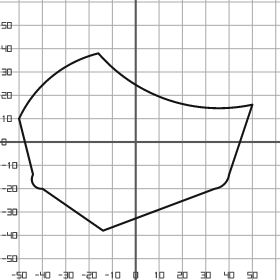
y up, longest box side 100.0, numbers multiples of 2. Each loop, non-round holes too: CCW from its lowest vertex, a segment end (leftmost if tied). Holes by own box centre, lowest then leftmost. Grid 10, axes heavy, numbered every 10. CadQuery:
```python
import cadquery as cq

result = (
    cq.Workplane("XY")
    .moveTo(-14.0, -38.0)
    .lineTo(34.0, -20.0)
    .threePointArc((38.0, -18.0), (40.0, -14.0))
    .lineTo(50.0, 16.0)
    .threePointArc((14.0, 18.0), (-16.0, 38.0))
    .threePointArc((-36.0, 28.0), (-50.0, 10.0))
    .lineTo(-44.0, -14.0)
    .threePointArc((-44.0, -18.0), (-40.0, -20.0))
    .close()
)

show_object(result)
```